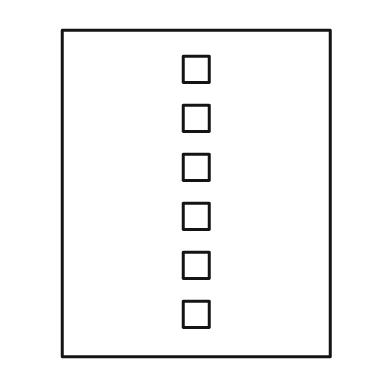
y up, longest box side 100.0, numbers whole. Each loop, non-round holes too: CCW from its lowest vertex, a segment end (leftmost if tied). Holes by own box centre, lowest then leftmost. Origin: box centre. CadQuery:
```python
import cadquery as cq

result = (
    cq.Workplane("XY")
    .moveTo(-41.0, -50.0)
    .lineTo(41.0, -50.0)
    .lineTo(41.0, 50.0)
    .lineTo(-41.0, 50.0)
    .close()
    .moveTo(-4.0, -41.0)
    .lineTo(4.0, -41.0)
    .lineTo(4.0, -33.0)
    .lineTo(-4.0, -33.0)
    .close()
    .moveTo(-4.0, -26.0)
    .lineTo(4.0, -26.0)
    .lineTo(4.0, -18.0)
    .lineTo(-4.0, -18.0)
    .close()
    .moveTo(-4.0, -11.0)
    .lineTo(4.0, -11.0)
    .lineTo(4.0, -3.0)
    .lineTo(-4.0, -3.0)
    .close()
    .moveTo(-4.0, 4.0)
    .lineTo(4.0, 4.0)
    .lineTo(4.0, 12.0)
    .lineTo(-4.0, 12.0)
    .close()
    .moveTo(-4.0, 19.0)
    .lineTo(4.0, 19.0)
    .lineTo(4.0, 27.0)
    .lineTo(-4.0, 27.0)
    .close()
    .moveTo(-4.0, 34.0)
    .lineTo(4.0, 34.0)
    .lineTo(4.0, 42.0)
    .lineTo(-4.0, 42.0)
    .close()
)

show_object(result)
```